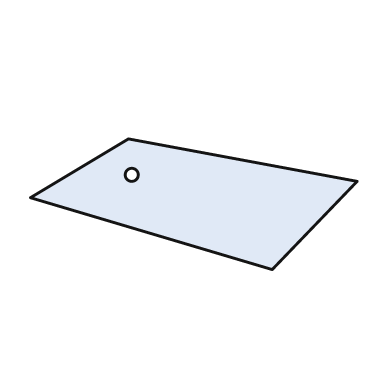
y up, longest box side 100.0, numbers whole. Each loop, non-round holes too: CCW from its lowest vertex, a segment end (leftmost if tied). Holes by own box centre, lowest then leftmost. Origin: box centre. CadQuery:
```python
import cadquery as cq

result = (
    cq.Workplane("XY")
    .moveTo(24.0, -20.0)
    .lineTo(50.0, 7.0)
    .lineTo(-20.0, 20.0)
    .lineTo(-50.0, 2.0)
    .close()
    .moveTo(-19.0, 9.0)
    .circle(2.0)
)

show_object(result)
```